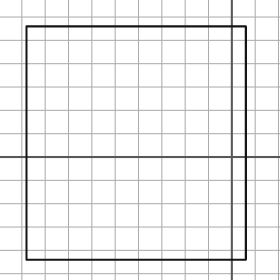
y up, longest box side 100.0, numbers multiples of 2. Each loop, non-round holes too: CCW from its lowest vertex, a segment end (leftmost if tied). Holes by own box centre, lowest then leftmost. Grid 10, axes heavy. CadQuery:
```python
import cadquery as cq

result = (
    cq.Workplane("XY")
    .moveTo(-88.0, -44.0)
    .lineTo(6.0, -44.0)
    .lineTo(6.0, 56.0)
    .lineTo(-88.0, 56.0)
    .close()
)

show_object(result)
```